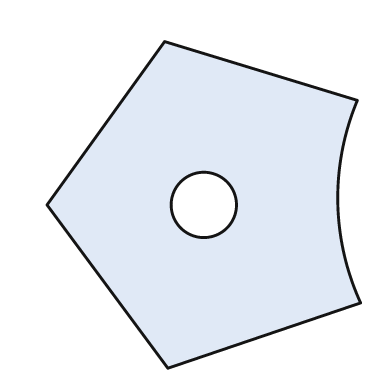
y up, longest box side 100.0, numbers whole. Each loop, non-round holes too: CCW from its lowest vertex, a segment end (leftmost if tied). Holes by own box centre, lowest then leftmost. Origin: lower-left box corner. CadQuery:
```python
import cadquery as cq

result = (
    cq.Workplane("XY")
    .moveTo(37.0, 0.0)
    .lineTo(96.0, 20.0)
    .threePointArc((89.0, 51.0), (95.0, 82.0))
    .lineTo(36.0, 100.0)
    .lineTo(0.0, 50.0)
    .close()
    .moveTo(48.0, 50.0)
    .circle(10.0)
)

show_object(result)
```